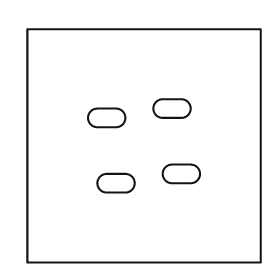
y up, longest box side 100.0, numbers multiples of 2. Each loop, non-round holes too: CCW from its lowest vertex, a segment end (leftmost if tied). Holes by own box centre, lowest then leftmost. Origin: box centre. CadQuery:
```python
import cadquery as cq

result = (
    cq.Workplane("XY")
    .moveTo(-50.0, -50.0)
    .lineTo(50.0, -50.0)
    .lineTo(50.0, 50.0)
    .lineTo(-50.0, 50.0)
    .close()
    .moveTo(-16.0, -20.0)
    .lineTo(-8.0, -20.0)
    .threePointArc((-4.0, -16.0), (-8.0, -12.0))
    .lineTo(-16.0, -12.0)
    .threePointArc((-20.0, -16.0), (-16.0, -20.0))
    .close()
    .moveTo(12.0, -16.0)
    .lineTo(20.0, -16.0)
    .threePointArc((24.0, -12.0), (20.0, -8.0))
    .lineTo(12.0, -8.0)
    .threePointArc((8.0, -12.0), (12.0, -16.0))
    .close()
    .moveTo(-20.0, 8.0)
    .lineTo(-12.0, 8.0)
    .threePointArc((-8.0, 12.0), (-12.0, 16.0))
    .lineTo(-20.0, 16.0)
    .threePointArc((-24.0, 12.0), (-20.0, 8.0))
    .close()
    .moveTo(8.0, 12.0)
    .lineTo(16.0, 12.0)
    .threePointArc((20.0, 16.0), (16.0, 20.0))
    .lineTo(8.0, 20.0)
    .threePointArc((4.0, 16.0), (8.0, 12.0))
    .close()
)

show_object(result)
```